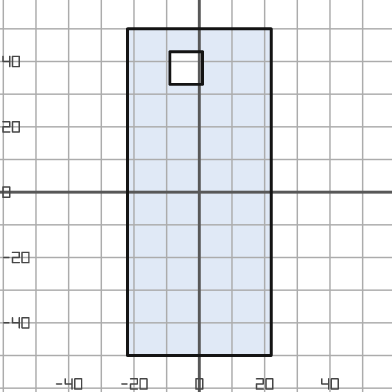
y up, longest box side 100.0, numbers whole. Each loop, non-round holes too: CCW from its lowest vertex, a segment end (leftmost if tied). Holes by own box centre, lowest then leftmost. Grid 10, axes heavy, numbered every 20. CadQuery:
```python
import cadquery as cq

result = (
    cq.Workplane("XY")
    .moveTo(-22.0, -50.0)
    .lineTo(22.0, -50.0)
    .lineTo(22.0, 50.0)
    .lineTo(-22.0, 50.0)
    .close()
    .moveTo(-9.0, 33.0)
    .lineTo(1.0, 33.0)
    .lineTo(1.0, 43.0)
    .lineTo(-9.0, 43.0)
    .close()
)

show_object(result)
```